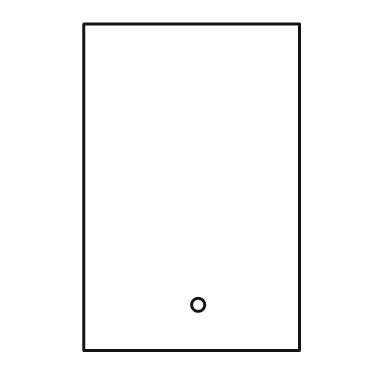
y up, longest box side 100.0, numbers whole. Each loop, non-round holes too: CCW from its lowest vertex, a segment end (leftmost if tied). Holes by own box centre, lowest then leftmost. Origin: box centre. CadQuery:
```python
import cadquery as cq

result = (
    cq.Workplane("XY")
    .moveTo(-33.0, -50.0)
    .lineTo(33.0, -50.0)
    .lineTo(33.0, 50.0)
    .lineTo(-33.0, 50.0)
    .close()
    .moveTo(2.0, -36.0)
    .circle(2.0)
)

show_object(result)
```